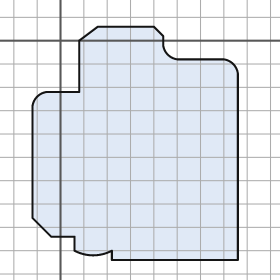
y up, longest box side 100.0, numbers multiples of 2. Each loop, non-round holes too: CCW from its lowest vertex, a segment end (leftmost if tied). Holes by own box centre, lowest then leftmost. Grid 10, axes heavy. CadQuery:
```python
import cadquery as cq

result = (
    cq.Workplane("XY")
    .moveTo(22.0, -94.0)
    .lineTo(76.0, -94.0)
    .lineTo(76.0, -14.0)
    .threePointArc((74.0, -10.0), (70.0, -8.0))
    .lineTo(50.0, -8.0)
    .threePointArc((46.0, -6.0), (44.0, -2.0))
    .lineTo(44.0, 2.0)
    .lineTo(40.0, 6.0)
    .lineTo(16.0, 6.0)
    .lineTo(8.0, 0.0)
    .lineTo(8.0, -22.0)
    .lineTo(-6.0, -22.0)
    .threePointArc((-10.0, -24.0), (-12.0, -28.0))
    .lineTo(-12.0, -76.0)
    .lineTo(-4.0, -84.0)
    .lineTo(6.0, -84.0)
    .lineTo(6.0, -90.0)
    .threePointArc((14.0, -92.0), (22.0, -90.0))
    .close()
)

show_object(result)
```